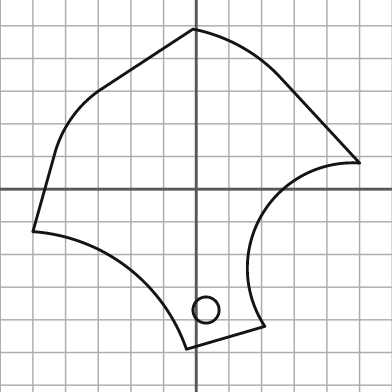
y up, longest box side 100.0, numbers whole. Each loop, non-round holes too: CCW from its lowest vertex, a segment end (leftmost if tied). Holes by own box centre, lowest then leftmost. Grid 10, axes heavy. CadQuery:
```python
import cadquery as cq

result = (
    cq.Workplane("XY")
    .moveTo(-3.0, -49.0)
    .lineTo(21.0, -42.0)
    .threePointArc((20.0, -8.0), (50.0, 8.0))
    .lineTo(25.0, 35.0)
    .threePointArc((13.0, 44.0), (-1.0, 49.0))
    .lineTo(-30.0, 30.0)
    .threePointArc((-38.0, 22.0), (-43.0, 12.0))
    .lineTo(-50.0, -13.0)
    .threePointArc((-21.0, -24.0), (-3.0, -49.0))
    .close()
    .moveTo(3.0, -37.0)
    .circle(4.0)
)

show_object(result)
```